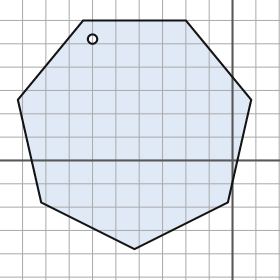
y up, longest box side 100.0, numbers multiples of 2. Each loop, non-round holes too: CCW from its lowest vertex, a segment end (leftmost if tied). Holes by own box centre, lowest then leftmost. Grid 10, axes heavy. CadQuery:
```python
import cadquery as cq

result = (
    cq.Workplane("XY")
    .moveTo(-42.0, -38.0)
    .lineTo(-2.0, -18.0)
    .lineTo(8.0, 26.0)
    .lineTo(-20.0, 60.0)
    .lineTo(-64.0, 60.0)
    .lineTo(-92.0, 26.0)
    .lineTo(-82.0, -18.0)
    .close()
    .moveTo(-60.0, 52.0)
    .circle(2.0)
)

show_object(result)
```